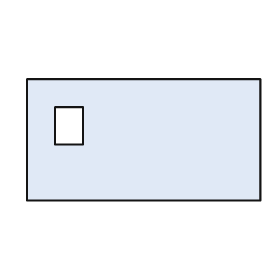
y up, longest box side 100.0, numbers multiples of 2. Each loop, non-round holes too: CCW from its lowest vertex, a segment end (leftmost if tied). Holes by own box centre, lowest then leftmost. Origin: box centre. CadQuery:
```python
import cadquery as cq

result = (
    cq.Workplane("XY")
    .moveTo(-50.0, -26.0)
    .lineTo(50.0, -26.0)
    .lineTo(50.0, 26.0)
    .lineTo(-50.0, 26.0)
    .close()
    .moveTo(-38.0, -2.0)
    .lineTo(-26.0, -2.0)
    .lineTo(-26.0, 14.0)
    .lineTo(-38.0, 14.0)
    .close()
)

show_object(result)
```